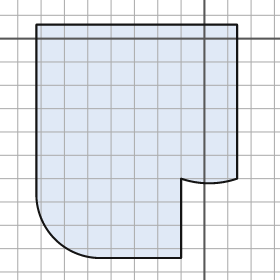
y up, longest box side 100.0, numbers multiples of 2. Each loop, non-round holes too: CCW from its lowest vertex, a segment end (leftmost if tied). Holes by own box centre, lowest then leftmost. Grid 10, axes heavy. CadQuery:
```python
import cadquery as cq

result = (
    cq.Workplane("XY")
    .moveTo(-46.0, -94.0)
    .lineTo(-10.0, -94.0)
    .lineTo(-10.0, -60.0)
    .threePointArc((2.0, -62.0), (14.0, -60.0))
    .lineTo(14.0, 6.0)
    .lineTo(-72.0, 6.0)
    .lineTo(-72.0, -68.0)
    .threePointArc((-64.0, -86.0), (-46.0, -94.0))
    .close()
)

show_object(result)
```